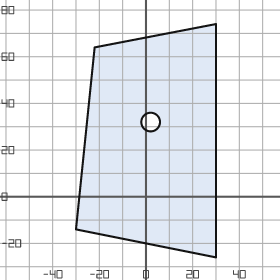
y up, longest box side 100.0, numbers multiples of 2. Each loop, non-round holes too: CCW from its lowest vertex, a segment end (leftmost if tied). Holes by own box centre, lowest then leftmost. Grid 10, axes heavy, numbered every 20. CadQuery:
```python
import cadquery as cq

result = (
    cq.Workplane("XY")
    .moveTo(30.0, -26.0)
    .lineTo(30.0, 74.0)
    .lineTo(-22.0, 64.0)
    .lineTo(-30.0, -14.0)
    .close()
    .moveTo(2.0, 32.0)
    .circle(4.0)
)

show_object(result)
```